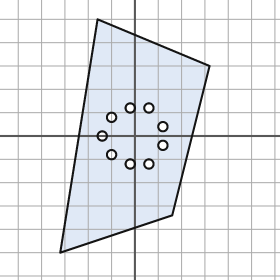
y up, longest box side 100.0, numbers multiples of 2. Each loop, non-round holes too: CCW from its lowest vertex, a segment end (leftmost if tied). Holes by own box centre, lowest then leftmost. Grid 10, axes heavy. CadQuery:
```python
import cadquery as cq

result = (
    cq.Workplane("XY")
    .moveTo(-32.0, -50.0)
    .lineTo(16.0, -34.0)
    .lineTo(32.0, 30.0)
    .lineTo(-16.0, 50.0)
    .close()
    .moveTo(-2.0, -12.0)
    .circle(2.0)
    .moveTo(6.0, -12.0)
    .circle(2.0)
    .moveTo(-10.0, -8.0)
    .circle(2.0)
    .moveTo(12.0, -4.0)
    .circle(2.0)
    .moveTo(-14.0, 0.0)
    .circle(2.0)
    .moveTo(12.0, 4.0)
    .circle(2.0)
    .moveTo(-10.0, 8.0)
    .circle(2.0)
    .moveTo(-2.0, 12.0)
    .circle(2.0)
    .moveTo(6.0, 12.0)
    .circle(2.0)
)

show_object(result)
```